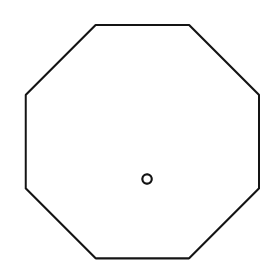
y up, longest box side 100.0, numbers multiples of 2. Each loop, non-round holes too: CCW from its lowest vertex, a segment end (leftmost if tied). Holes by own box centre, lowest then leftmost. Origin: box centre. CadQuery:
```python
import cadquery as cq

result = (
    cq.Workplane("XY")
    .moveTo(-20.0, -50.0)
    .lineTo(20.0, -50.0)
    .lineTo(50.0, -20.0)
    .lineTo(50.0, 20.0)
    .lineTo(20.0, 50.0)
    .lineTo(-20.0, 50.0)
    .lineTo(-50.0, 20.0)
    .lineTo(-50.0, -20.0)
    .close()
    .moveTo(2.0, -16.0)
    .circle(2.0)
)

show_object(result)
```